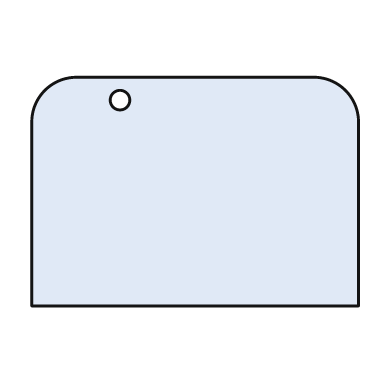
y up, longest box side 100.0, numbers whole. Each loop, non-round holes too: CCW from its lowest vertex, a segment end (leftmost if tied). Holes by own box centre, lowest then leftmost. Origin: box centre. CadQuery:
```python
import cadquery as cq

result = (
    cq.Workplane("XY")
    .moveTo(-50.0, -35.0)
    .lineTo(50.0, -35.0)
    .lineTo(50.0, 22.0)
    .threePointArc((46.0, 31.0), (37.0, 35.0))
    .lineTo(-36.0, 35.0)
    .threePointArc((-46.0, 31.0), (-50.0, 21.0))
    .close()
    .moveTo(-23.0, 28.0)
    .circle(3.0)
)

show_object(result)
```